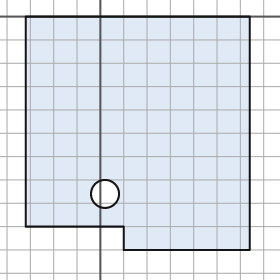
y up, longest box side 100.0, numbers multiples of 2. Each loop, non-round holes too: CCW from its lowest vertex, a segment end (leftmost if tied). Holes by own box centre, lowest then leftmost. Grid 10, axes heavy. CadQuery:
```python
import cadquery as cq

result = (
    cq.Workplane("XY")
    .moveTo(10.0, -100.0)
    .lineTo(64.0, -100.0)
    .lineTo(64.0, 0.0)
    .lineTo(-32.0, 0.0)
    .lineTo(-32.0, -90.0)
    .lineTo(10.0, -90.0)
    .close()
    .moveTo(2.0, -76.0)
    .circle(6.0)
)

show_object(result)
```